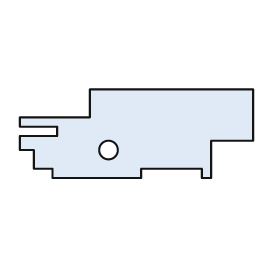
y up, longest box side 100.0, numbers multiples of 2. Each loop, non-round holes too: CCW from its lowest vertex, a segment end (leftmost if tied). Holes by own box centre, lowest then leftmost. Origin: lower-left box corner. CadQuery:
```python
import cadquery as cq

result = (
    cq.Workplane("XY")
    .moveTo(14.0, 0.0)
    .lineTo(52.0, 0.0)
    .lineTo(52.0, 4.0)
    .lineTo(78.0, 4.0)
    .lineTo(78.0, 0.0)
    .lineTo(82.0, 0.0)
    .lineTo(82.0, 16.0)
    .lineTo(100.0, 16.0)
    .lineTo(100.0, 38.0)
    .lineTo(30.0, 38.0)
    .lineTo(30.0, 26.0)
    .lineTo(0.0, 26.0)
    .lineTo(0.0, 22.0)
    .lineTo(16.0, 22.0)
    .lineTo(16.0, 18.0)
    .lineTo(0.0, 18.0)
    .lineTo(0.0, 12.0)
    .lineTo(6.0, 12.0)
    .lineTo(6.0, 4.0)
    .lineTo(14.0, 4.0)
    .close()
    .moveTo(38.0, 12.0)
    .circle(4.0)
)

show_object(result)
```